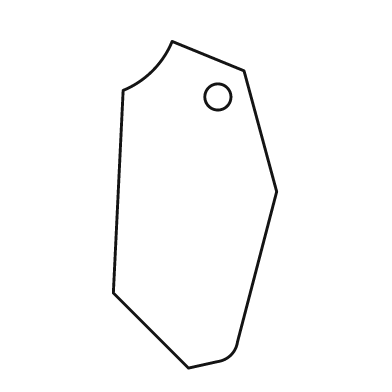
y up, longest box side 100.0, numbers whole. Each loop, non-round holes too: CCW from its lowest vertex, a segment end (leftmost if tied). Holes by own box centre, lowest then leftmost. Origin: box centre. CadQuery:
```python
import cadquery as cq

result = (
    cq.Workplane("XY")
    .moveTo(-2.0, -50.0)
    .lineTo(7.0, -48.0)
    .threePointArc((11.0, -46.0), (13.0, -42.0))
    .lineTo(25.0, 4.0)
    .lineTo(15.0, 41.0)
    .lineTo(-7.0, 50.0)
    .threePointArc((-13.0, 41.0), (-22.0, 35.0))
    .lineTo(-25.0, -27.0)
    .close()
    .moveTo(7.0, 33.0)
    .circle(4.0)
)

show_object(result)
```